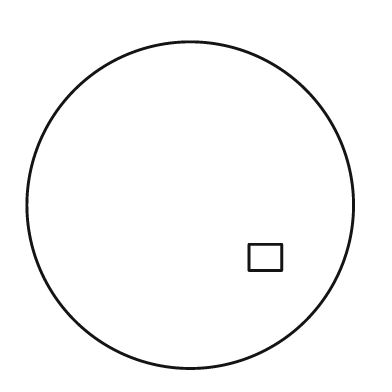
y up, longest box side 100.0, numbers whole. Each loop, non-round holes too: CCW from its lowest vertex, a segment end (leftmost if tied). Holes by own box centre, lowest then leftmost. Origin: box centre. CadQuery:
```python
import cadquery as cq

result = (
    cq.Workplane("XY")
    .moveTo(0.0, 0.0)
    .circle(50.0)
    .moveTo(18.0, -20.0)
    .lineTo(28.0, -20.0)
    .lineTo(28.0, -12.0)
    .lineTo(18.0, -12.0)
    .close()
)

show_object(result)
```